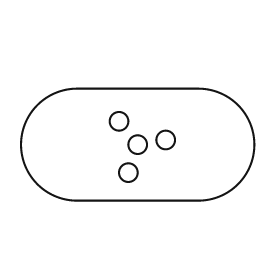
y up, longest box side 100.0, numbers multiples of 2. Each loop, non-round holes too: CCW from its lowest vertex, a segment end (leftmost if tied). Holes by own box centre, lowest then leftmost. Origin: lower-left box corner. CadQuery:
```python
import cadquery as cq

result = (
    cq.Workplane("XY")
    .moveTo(24.0, 0.0)
    .lineTo(76.0, 0.0)
    .threePointArc((100.0, 24.0), (76.0, 48.0))
    .lineTo(24.0, 48.0)
    .threePointArc((0.0, 24.0), (24.0, 0.0))
    .close()
    .moveTo(46.0, 12.0)
    .circle(4.0)
    .moveTo(50.0, 24.0)
    .circle(4.0)
    .moveTo(62.0, 26.0)
    .circle(4.0)
    .moveTo(42.0, 34.0)
    .circle(4.0)
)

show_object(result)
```